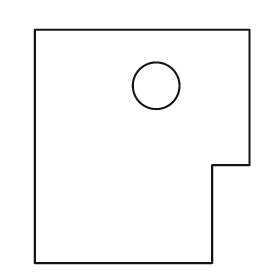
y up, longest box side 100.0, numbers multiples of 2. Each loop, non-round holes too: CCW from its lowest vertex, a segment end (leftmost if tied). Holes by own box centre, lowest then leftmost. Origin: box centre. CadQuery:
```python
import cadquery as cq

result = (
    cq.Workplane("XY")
    .moveTo(-46.0, -50.0)
    .lineTo(30.0, -50.0)
    .lineTo(30.0, -8.0)
    .lineTo(46.0, -8.0)
    .lineTo(46.0, 50.0)
    .lineTo(-46.0, 50.0)
    .close()
    .moveTo(6.0, 26.0)
    .circle(10.0)
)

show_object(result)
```